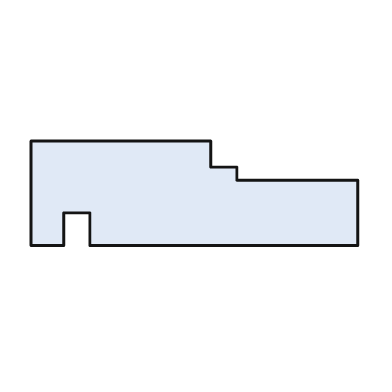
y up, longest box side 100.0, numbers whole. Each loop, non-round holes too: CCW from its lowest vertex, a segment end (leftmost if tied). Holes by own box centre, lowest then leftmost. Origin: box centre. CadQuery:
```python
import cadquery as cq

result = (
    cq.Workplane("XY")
    .moveTo(-50.0, -16.0)
    .lineTo(-40.0, -16.0)
    .lineTo(-40.0, -6.0)
    .lineTo(-32.0, -6.0)
    .lineTo(-32.0, -16.0)
    .lineTo(50.0, -16.0)
    .lineTo(50.0, 4.0)
    .lineTo(13.0, 4.0)
    .lineTo(13.0, 8.0)
    .lineTo(5.0, 8.0)
    .lineTo(5.0, 16.0)
    .lineTo(-50.0, 16.0)
    .close()
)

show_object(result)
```